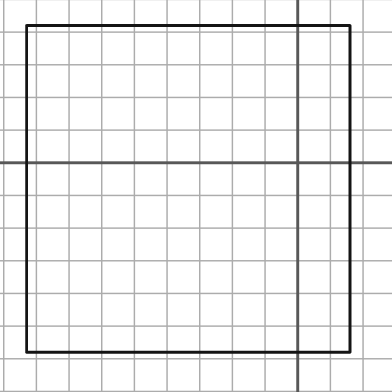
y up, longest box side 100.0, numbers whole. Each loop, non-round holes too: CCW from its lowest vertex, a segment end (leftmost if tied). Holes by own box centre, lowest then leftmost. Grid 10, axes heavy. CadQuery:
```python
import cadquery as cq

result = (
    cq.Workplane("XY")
    .moveTo(-83.0, -58.0)
    .lineTo(16.0, -58.0)
    .lineTo(16.0, 42.0)
    .lineTo(-83.0, 42.0)
    .close()
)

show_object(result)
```